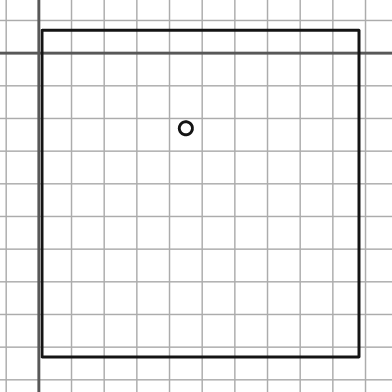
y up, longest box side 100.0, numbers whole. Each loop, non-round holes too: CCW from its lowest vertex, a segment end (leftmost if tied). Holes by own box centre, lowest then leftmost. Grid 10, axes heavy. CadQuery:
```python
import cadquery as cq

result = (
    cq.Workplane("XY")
    .moveTo(1.0, -93.0)
    .lineTo(98.0, -93.0)
    .lineTo(98.0, 7.0)
    .lineTo(1.0, 7.0)
    .close()
    .moveTo(45.0, -23.0)
    .circle(2.0)
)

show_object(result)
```